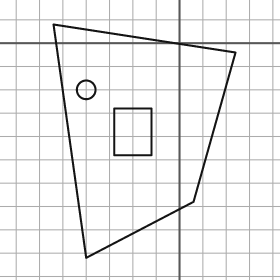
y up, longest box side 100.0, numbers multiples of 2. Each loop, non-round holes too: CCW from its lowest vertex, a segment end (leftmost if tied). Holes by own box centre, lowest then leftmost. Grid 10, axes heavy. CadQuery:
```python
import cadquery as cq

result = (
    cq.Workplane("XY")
    .moveTo(-40.0, -92.0)
    .lineTo(6.0, -68.0)
    .lineTo(24.0, -4.0)
    .lineTo(-54.0, 8.0)
    .close()
    .moveTo(-28.0, -48.0)
    .lineTo(-12.0, -48.0)
    .lineTo(-12.0, -28.0)
    .lineTo(-28.0, -28.0)
    .close()
    .moveTo(-40.0, -20.0)
    .circle(4.0)
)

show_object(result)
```